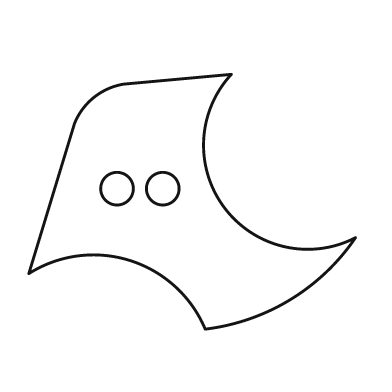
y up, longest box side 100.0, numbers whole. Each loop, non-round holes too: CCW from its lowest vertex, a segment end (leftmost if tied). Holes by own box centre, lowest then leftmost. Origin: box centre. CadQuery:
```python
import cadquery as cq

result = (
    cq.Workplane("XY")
    .moveTo(4.0, -39.0)
    .threePointArc((30.0, -30.0), (50.0, -11.0))
    .threePointArc((10.0, -2.0), (12.0, 39.0))
    .lineTo(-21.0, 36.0)
    .threePointArc((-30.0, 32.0), (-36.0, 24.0))
    .lineTo(-50.0, -22.0)
    .threePointArc((-19.0, -18.0), (4.0, -39.0))
    .close()
    .moveTo(-23.0, 4.0)
    .circle(5.0)
    .moveTo(-9.0, 4.0)
    .circle(5.0)
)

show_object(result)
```